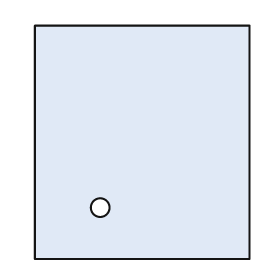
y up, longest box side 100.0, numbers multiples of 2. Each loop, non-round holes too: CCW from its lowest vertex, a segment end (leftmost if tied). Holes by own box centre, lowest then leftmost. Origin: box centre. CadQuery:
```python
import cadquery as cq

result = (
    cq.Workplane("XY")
    .moveTo(-46.0, -50.0)
    .lineTo(46.0, -50.0)
    .lineTo(46.0, 50.0)
    .lineTo(-46.0, 50.0)
    .close()
    .moveTo(-18.0, -28.0)
    .circle(4.0)
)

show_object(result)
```